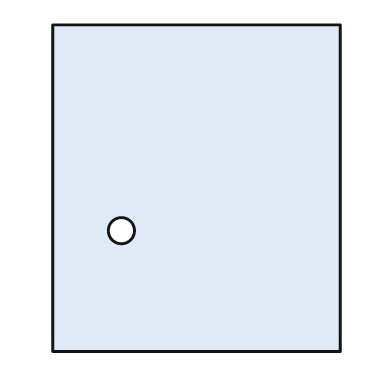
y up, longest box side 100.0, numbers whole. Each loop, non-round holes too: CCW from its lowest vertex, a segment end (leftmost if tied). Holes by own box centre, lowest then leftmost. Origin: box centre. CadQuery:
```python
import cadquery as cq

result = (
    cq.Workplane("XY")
    .moveTo(-44.0, -50.0)
    .lineTo(44.0, -50.0)
    .lineTo(44.0, 50.0)
    .lineTo(-44.0, 50.0)
    .close()
    .moveTo(-23.0, -13.0)
    .circle(4.0)
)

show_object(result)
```